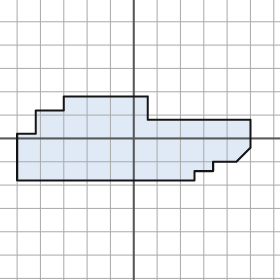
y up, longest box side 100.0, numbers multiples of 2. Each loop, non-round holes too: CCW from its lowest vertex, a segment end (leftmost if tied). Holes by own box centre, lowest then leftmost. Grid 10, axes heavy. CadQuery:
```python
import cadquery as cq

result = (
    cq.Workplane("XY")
    .moveTo(-50.0, -18.0)
    .lineTo(26.0, -18.0)
    .lineTo(26.0, -14.0)
    .lineTo(34.0, -14.0)
    .lineTo(34.0, -10.0)
    .lineTo(44.0, -10.0)
    .lineTo(50.0, -4.0)
    .lineTo(50.0, 8.0)
    .lineTo(6.0, 8.0)
    .lineTo(6.0, 18.0)
    .lineTo(-30.0, 18.0)
    .lineTo(-30.0, 12.0)
    .lineTo(-42.0, 12.0)
    .lineTo(-42.0, 2.0)
    .lineTo(-50.0, 2.0)
    .close()
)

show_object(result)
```